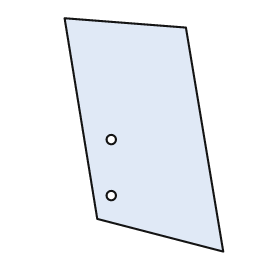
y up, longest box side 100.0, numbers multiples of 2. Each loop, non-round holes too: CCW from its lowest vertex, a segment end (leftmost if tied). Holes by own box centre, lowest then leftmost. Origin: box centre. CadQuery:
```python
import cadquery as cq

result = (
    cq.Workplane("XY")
    .moveTo(34.0, -50.0)
    .lineTo(18.0, 46.0)
    .lineTo(-34.0, 50.0)
    .lineTo(-20.0, -36.0)
    .close()
    .moveTo(-14.0, -26.0)
    .circle(2.0)
    .moveTo(-14.0, -2.0)
    .circle(2.0)
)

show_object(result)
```